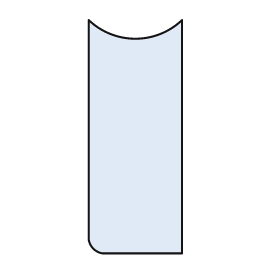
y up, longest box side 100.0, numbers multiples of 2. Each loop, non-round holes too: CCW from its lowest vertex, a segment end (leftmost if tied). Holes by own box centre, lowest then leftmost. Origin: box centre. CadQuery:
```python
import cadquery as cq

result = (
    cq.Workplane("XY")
    .moveTo(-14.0, -50.0)
    .lineTo(20.0, -50.0)
    .lineTo(20.0, 50.0)
    .threePointArc((0.0, 42.0), (-20.0, 50.0))
    .lineTo(-20.0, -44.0)
    .threePointArc((-18.0, -48.0), (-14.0, -50.0))
    .close()
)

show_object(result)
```